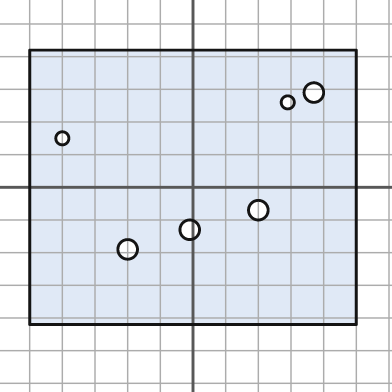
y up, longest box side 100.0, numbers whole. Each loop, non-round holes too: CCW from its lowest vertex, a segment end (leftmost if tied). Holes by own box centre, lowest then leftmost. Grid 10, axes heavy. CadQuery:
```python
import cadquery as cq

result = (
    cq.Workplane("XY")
    .moveTo(-50.0, -42.0)
    .lineTo(50.0, -42.0)
    .lineTo(50.0, 42.0)
    .lineTo(-50.0, 42.0)
    .close()
    .moveTo(-20.0, -19.0)
    .circle(3.0)
    .moveTo(-1.0, -13.0)
    .circle(3.0)
    .moveTo(20.0, -7.0)
    .circle(3.0)
    .moveTo(-40.0, 15.0)
    .circle(2.0)
    .moveTo(29.0, 26.0)
    .circle(2.0)
    .moveTo(37.0, 29.0)
    .circle(3.0)
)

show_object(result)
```